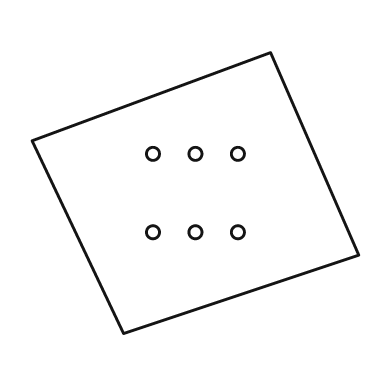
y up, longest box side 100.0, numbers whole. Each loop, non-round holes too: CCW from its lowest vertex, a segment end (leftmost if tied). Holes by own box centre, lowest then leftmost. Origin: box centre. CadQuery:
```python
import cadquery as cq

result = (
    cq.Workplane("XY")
    .moveTo(-22.0, -43.0)
    .lineTo(50.0, -19.0)
    .lineTo(23.0, 43.0)
    .lineTo(-50.0, 16.0)
    .close()
    .moveTo(-13.0, -12.0)
    .circle(2.0)
    .moveTo(0.0, -12.0)
    .circle(2.0)
    .moveTo(13.0, -12.0)
    .circle(2.0)
    .moveTo(-13.0, 12.0)
    .circle(2.0)
    .moveTo(0.0, 12.0)
    .circle(2.0)
    .moveTo(13.0, 12.0)
    .circle(2.0)
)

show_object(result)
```